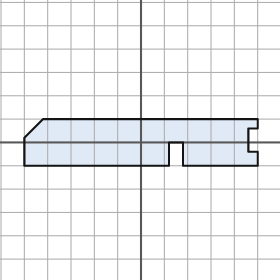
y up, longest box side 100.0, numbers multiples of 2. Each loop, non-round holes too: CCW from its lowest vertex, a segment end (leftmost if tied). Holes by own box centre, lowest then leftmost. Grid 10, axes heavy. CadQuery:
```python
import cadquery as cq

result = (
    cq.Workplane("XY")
    .moveTo(-50.0, -10.0)
    .lineTo(12.0, -10.0)
    .lineTo(12.0, 0.0)
    .lineTo(18.0, 0.0)
    .lineTo(18.0, -10.0)
    .lineTo(50.0, -10.0)
    .lineTo(50.0, -4.0)
    .lineTo(46.0, -4.0)
    .lineTo(46.0, 6.0)
    .lineTo(50.0, 6.0)
    .lineTo(50.0, 10.0)
    .lineTo(-42.0, 10.0)
    .lineTo(-50.0, 2.0)
    .close()
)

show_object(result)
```